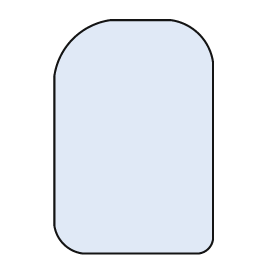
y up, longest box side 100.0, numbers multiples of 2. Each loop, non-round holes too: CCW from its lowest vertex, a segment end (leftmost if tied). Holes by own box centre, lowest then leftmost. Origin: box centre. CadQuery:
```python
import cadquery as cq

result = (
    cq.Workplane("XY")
    .moveTo(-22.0, -50.0)
    .lineTo(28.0, -50.0)
    .threePointArc((32.0, -48.0), (34.0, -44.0))
    .lineTo(34.0, 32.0)
    .threePointArc((28.0, 44.0), (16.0, 50.0))
    .lineTo(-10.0, 50.0)
    .threePointArc((-26.0, 42.0), (-34.0, 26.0))
    .lineTo(-34.0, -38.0)
    .threePointArc((-30.0, -46.0), (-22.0, -50.0))
    .close()
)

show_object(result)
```